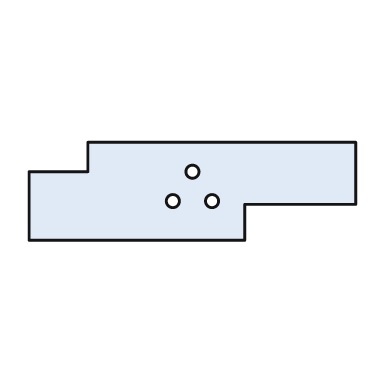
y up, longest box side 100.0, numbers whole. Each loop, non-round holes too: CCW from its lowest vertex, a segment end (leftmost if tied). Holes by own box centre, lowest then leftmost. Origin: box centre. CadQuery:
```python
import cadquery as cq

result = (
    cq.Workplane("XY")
    .moveTo(-50.0, -15.0)
    .lineTo(16.0, -15.0)
    .lineTo(16.0, -4.0)
    .lineTo(50.0, -4.0)
    .lineTo(50.0, 15.0)
    .lineTo(-32.0, 15.0)
    .lineTo(-32.0, 6.0)
    .lineTo(-50.0, 6.0)
    .close()
    .moveTo(-6.0, -3.0)
    .circle(2.0)
    .moveTo(6.0, -3.0)
    .circle(2.0)
    .moveTo(0.0, 6.0)
    .circle(2.0)
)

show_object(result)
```